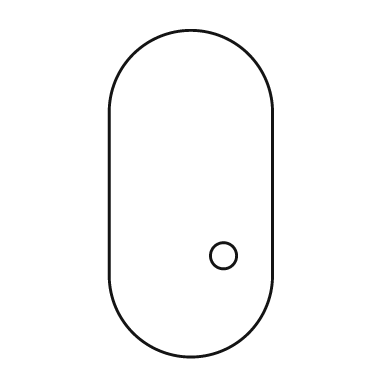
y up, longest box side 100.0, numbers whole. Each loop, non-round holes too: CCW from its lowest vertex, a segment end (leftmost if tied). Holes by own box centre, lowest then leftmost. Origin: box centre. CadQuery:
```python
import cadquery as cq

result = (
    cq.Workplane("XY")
    .moveTo(-25.0, -25.0)
    .threePointArc((0.0, -50.0), (25.0, -25.0))
    .lineTo(25.0, 25.0)
    .threePointArc((0.0, 50.0), (-25.0, 25.0))
    .close()
    .moveTo(10.0, -19.0)
    .circle(4.0)
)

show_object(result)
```